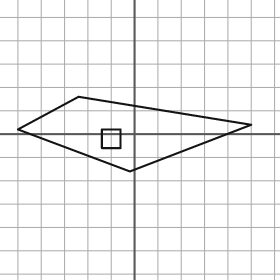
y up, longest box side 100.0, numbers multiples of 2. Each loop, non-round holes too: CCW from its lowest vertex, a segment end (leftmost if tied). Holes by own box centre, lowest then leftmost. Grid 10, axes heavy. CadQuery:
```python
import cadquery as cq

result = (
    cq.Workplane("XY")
    .moveTo(-2.0, -16.0)
    .lineTo(50.0, 4.0)
    .lineTo(-24.0, 16.0)
    .lineTo(-50.0, 2.0)
    .close()
    .moveTo(-14.0, -6.0)
    .lineTo(-6.0, -6.0)
    .lineTo(-6.0, 2.0)
    .lineTo(-14.0, 2.0)
    .close()
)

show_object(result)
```